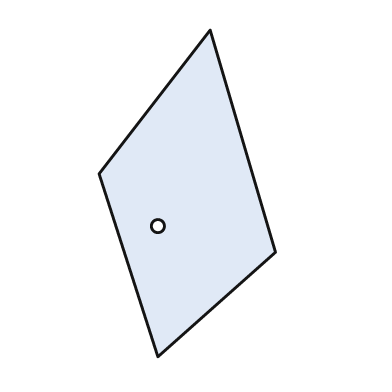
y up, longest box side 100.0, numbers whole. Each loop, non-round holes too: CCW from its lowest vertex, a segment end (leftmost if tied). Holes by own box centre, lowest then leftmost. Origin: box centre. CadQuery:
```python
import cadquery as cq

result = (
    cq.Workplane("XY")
    .moveTo(-9.0, -50.0)
    .lineTo(27.0, -18.0)
    .lineTo(7.0, 50.0)
    .lineTo(-27.0, 6.0)
    .close()
    .moveTo(-9.0, -10.0)
    .circle(2.0)
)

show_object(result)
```